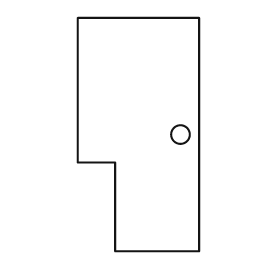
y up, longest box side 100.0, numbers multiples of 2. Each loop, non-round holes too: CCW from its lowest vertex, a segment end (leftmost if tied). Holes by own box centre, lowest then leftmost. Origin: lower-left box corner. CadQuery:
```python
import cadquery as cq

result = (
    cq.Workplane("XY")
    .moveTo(16.0, 0.0)
    .lineTo(52.0, 0.0)
    .lineTo(52.0, 100.0)
    .lineTo(0.0, 100.0)
    .lineTo(0.0, 38.0)
    .lineTo(16.0, 38.0)
    .close()
    .moveTo(44.0, 50.0)
    .circle(4.0)
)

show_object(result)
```